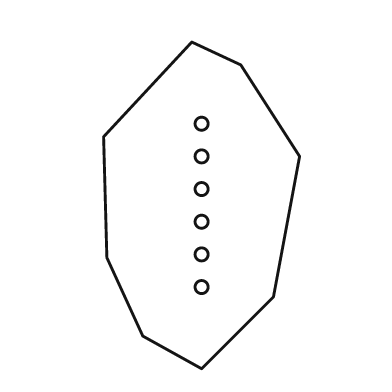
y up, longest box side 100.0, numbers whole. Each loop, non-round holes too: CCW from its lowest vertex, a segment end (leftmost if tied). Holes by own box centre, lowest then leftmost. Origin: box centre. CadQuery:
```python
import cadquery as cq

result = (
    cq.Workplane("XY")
    .moveTo(0.0, -50.0)
    .lineTo(22.0, -28.0)
    .lineTo(30.0, 15.0)
    .lineTo(12.0, 43.0)
    .lineTo(-3.0, 50.0)
    .lineTo(-30.0, 21.0)
    .lineTo(-29.0, -16.0)
    .lineTo(-18.0, -40.0)
    .close()
    .moveTo(0.0, -25.0)
    .circle(2.0)
    .moveTo(0.0, -15.0)
    .circle(2.0)
    .moveTo(0.0, -5.0)
    .circle(2.0)
    .moveTo(0.0, 5.0)
    .circle(2.0)
    .moveTo(0.0, 15.0)
    .circle(2.0)
    .moveTo(0.0, 25.0)
    .circle(2.0)
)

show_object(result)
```